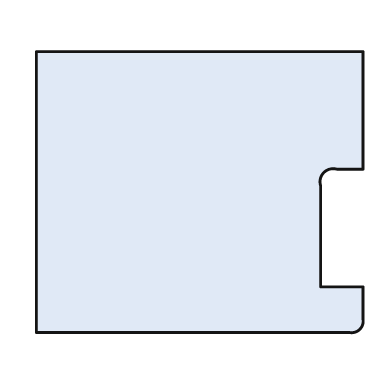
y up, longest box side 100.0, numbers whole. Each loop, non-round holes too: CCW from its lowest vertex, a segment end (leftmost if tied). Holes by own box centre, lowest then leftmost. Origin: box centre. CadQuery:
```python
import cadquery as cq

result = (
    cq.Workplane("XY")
    .moveTo(-50.0, -43.0)
    .lineTo(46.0, -43.0)
    .threePointArc((49.0, -42.0), (50.0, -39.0))
    .lineTo(50.0, -29.0)
    .lineTo(37.0, -29.0)
    .lineTo(37.0, 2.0)
    .threePointArc((38.0, 6.0), (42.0, 7.0))
    .lineTo(50.0, 7.0)
    .lineTo(50.0, 43.0)
    .lineTo(-50.0, 43.0)
    .close()
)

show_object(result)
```